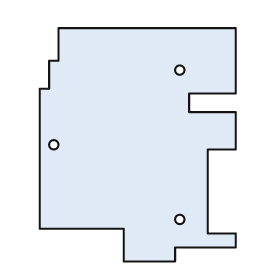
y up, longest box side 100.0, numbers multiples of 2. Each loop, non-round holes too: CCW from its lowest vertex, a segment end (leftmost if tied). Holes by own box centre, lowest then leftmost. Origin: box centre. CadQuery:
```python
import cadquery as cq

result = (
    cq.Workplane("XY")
    .moveTo(-6.0, -50.0)
    .lineTo(16.0, -50.0)
    .lineTo(16.0, -44.0)
    .lineTo(42.0, -44.0)
    .lineTo(42.0, -38.0)
    .lineTo(30.0, -38.0)
    .lineTo(30.0, -2.0)
    .lineTo(42.0, -2.0)
    .lineTo(42.0, 14.0)
    .lineTo(22.0, 14.0)
    .lineTo(22.0, 22.0)
    .lineTo(42.0, 22.0)
    .lineTo(42.0, 50.0)
    .lineTo(-34.0, 50.0)
    .lineTo(-34.0, 36.0)
    .lineTo(-38.0, 36.0)
    .lineTo(-38.0, 24.0)
    .lineTo(-42.0, 24.0)
    .lineTo(-42.0, -36.0)
    .lineTo(-6.0, -36.0)
    .close()
    .moveTo(18.0, -32.0)
    .circle(2.0)
    .moveTo(-36.0, 0.0)
    .circle(2.0)
    .moveTo(18.0, 32.0)
    .circle(2.0)
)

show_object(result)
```